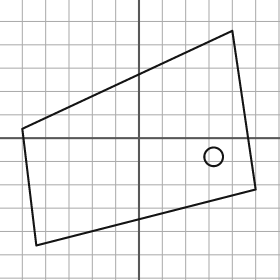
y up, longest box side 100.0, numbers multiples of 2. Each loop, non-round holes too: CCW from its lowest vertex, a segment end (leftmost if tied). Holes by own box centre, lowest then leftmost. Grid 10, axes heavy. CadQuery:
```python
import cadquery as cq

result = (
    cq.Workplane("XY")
    .moveTo(-44.0, -46.0)
    .lineTo(50.0, -22.0)
    .lineTo(40.0, 46.0)
    .lineTo(-50.0, 4.0)
    .close()
    .moveTo(32.0, -8.0)
    .circle(4.0)
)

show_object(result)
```